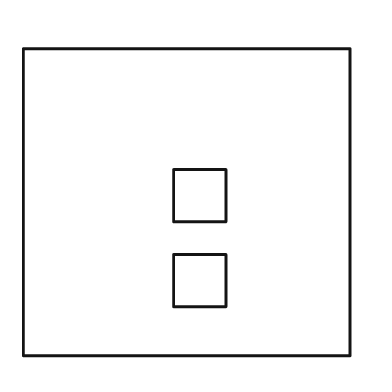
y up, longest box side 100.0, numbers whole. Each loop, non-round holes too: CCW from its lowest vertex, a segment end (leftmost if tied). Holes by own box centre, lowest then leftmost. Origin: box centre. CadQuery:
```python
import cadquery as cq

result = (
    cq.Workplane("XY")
    .moveTo(-50.0, -47.0)
    .lineTo(50.0, -47.0)
    .lineTo(50.0, 47.0)
    .lineTo(-50.0, 47.0)
    .close()
    .moveTo(-4.0, -32.0)
    .lineTo(12.0, -32.0)
    .lineTo(12.0, -16.0)
    .lineTo(-4.0, -16.0)
    .close()
    .moveTo(-4.0, -6.0)
    .lineTo(12.0, -6.0)
    .lineTo(12.0, 10.0)
    .lineTo(-4.0, 10.0)
    .close()
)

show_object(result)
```